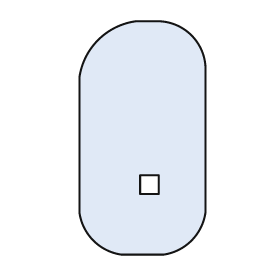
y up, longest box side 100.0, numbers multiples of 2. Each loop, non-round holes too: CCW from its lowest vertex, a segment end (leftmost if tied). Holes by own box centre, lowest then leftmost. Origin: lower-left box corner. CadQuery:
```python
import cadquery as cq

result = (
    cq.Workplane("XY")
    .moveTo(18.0, 0.0)
    .lineTo(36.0, 0.0)
    .threePointArc((48.0, 6.0), (54.0, 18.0))
    .lineTo(54.0, 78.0)
    .threePointArc((48.0, 94.0), (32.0, 100.0))
    .lineTo(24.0, 100.0)
    .threePointArc((8.0, 92.0), (0.0, 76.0))
    .lineTo(0.0, 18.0)
    .threePointArc((6.0, 6.0), (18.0, 0.0))
    .close()
    .moveTo(26.0, 26.0)
    .lineTo(34.0, 26.0)
    .lineTo(34.0, 34.0)
    .lineTo(26.0, 34.0)
    .close()
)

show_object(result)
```